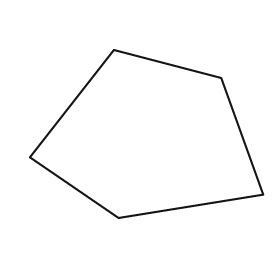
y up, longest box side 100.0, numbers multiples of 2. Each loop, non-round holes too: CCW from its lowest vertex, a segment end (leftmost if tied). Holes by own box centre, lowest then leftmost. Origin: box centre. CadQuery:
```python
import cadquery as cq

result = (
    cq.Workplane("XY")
    .moveTo(-12.0, -36.0)
    .lineTo(50.0, -26.0)
    .lineTo(32.0, 24.0)
    .lineTo(-14.0, 36.0)
    .lineTo(-50.0, -10.0)
    .close()
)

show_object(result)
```